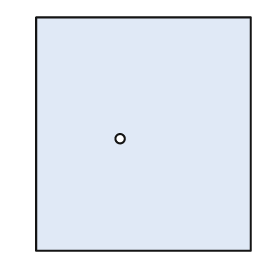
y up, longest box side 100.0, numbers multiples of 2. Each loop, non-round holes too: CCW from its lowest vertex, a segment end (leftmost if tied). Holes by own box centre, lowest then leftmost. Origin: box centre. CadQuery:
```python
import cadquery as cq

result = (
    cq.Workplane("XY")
    .moveTo(-46.0, -50.0)
    .lineTo(46.0, -50.0)
    .lineTo(46.0, 50.0)
    .lineTo(-46.0, 50.0)
    .close()
    .moveTo(-10.0, -2.0)
    .circle(2.0)
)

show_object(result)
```